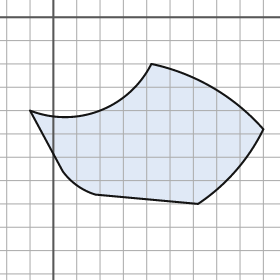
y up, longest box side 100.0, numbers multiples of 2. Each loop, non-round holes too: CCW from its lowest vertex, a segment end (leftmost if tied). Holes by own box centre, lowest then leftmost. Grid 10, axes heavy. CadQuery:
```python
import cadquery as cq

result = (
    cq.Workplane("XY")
    .moveTo(62.0, -80.0)
    .threePointArc((78.0, -66.0), (90.0, -48.0))
    .threePointArc((68.0, -30.0), (42.0, -20.0))
    .threePointArc((20.0, -40.0), (-10.0, -40.0))
    .lineTo(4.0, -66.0)
    .threePointArc((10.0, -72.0), (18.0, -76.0))
    .close()
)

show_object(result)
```